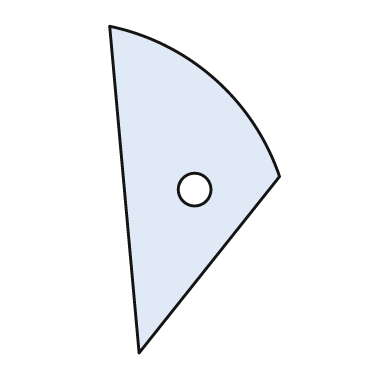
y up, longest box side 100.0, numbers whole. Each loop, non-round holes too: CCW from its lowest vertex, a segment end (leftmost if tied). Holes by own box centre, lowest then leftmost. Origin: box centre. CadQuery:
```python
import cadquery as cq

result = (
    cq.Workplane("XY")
    .moveTo(-17.0, -50.0)
    .lineTo(26.0, 4.0)
    .threePointArc((6.0, 34.0), (-26.0, 50.0))
    .close()
    .moveTo(0.0, 0.0)
    .circle(5.0)
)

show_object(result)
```